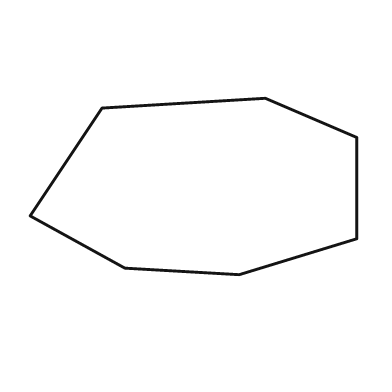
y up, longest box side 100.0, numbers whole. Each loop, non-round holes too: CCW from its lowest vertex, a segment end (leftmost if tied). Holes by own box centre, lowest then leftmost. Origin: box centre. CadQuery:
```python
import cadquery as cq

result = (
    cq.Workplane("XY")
    .moveTo(14.0, -27.0)
    .lineTo(50.0, -16.0)
    .lineTo(50.0, 15.0)
    .lineTo(22.0, 27.0)
    .lineTo(-28.0, 24.0)
    .lineTo(-50.0, -9.0)
    .lineTo(-21.0, -25.0)
    .close()
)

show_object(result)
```